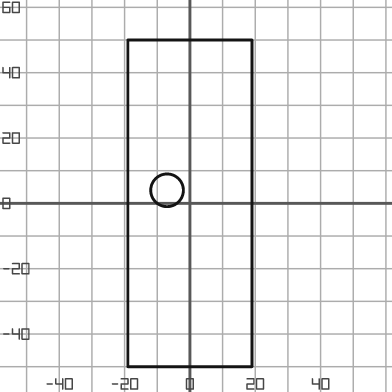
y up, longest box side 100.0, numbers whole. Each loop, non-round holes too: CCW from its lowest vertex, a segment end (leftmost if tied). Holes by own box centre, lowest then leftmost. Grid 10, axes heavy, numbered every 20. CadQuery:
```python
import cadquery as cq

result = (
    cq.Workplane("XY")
    .moveTo(-19.0, -50.0)
    .lineTo(19.0, -50.0)
    .lineTo(19.0, 50.0)
    .lineTo(-19.0, 50.0)
    .close()
    .moveTo(-7.0, 4.0)
    .circle(5.0)
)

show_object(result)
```